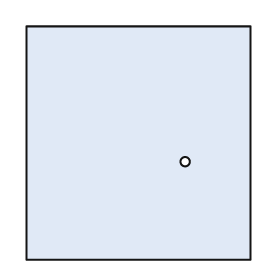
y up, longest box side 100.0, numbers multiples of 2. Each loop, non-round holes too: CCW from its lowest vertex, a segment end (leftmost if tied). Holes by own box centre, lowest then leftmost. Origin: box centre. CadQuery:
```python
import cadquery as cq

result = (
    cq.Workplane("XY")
    .moveTo(-48.0, -50.0)
    .lineTo(48.0, -50.0)
    .lineTo(48.0, 50.0)
    .lineTo(-48.0, 50.0)
    .close()
    .moveTo(20.0, -8.0)
    .circle(2.0)
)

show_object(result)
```